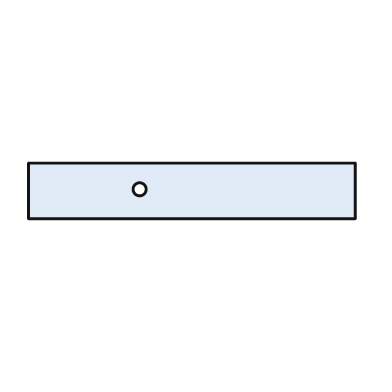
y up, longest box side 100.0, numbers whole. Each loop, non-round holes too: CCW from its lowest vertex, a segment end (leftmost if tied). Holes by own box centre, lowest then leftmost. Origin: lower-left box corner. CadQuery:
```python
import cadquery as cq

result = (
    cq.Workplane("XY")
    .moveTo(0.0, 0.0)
    .lineTo(100.0, 0.0)
    .lineTo(100.0, 17.0)
    .lineTo(0.0, 17.0)
    .close()
    .moveTo(34.0, 9.0)
    .circle(2.0)
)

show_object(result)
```